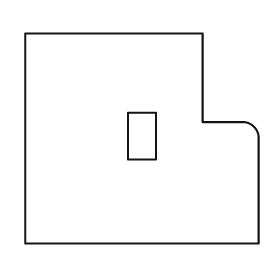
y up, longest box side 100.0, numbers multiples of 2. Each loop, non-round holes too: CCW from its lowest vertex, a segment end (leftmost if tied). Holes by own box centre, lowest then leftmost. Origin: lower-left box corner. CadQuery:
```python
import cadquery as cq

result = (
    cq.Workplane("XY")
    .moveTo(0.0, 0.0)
    .lineTo(100.0, 0.0)
    .lineTo(100.0, 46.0)
    .threePointArc((98.0, 50.0), (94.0, 52.0))
    .lineTo(76.0, 52.0)
    .lineTo(76.0, 90.0)
    .lineTo(0.0, 90.0)
    .close()
    .moveTo(44.0, 36.0)
    .lineTo(56.0, 36.0)
    .lineTo(56.0, 56.0)
    .lineTo(44.0, 56.0)
    .close()
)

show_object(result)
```